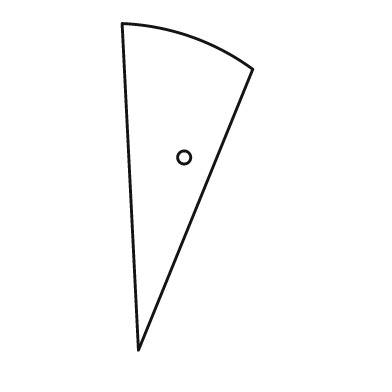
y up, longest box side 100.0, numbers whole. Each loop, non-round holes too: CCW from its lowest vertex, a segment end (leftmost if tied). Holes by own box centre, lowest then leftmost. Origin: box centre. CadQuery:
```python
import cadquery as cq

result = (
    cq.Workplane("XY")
    .moveTo(-15.0, -50.0)
    .lineTo(20.0, 36.0)
    .threePointArc((1.0, 46.0), (-20.0, 50.0))
    .close()
    .moveTo(-1.0, 9.0)
    .circle(2.0)
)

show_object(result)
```